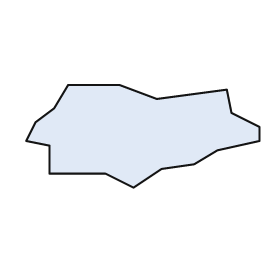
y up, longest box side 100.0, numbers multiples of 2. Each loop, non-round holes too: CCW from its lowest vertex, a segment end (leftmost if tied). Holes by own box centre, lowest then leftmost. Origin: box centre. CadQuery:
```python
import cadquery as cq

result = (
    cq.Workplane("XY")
    .moveTo(-4.0, -22.0)
    .lineTo(8.0, -14.0)
    .lineTo(22.0, -12.0)
    .lineTo(32.0, -6.0)
    .lineTo(50.0, -2.0)
    .lineTo(50.0, 4.0)
    .lineTo(38.0, 10.0)
    .lineTo(36.0, 20.0)
    .lineTo(6.0, 16.0)
    .lineTo(-10.0, 22.0)
    .lineTo(-32.0, 22.0)
    .lineTo(-38.0, 12.0)
    .lineTo(-46.0, 6.0)
    .lineTo(-50.0, -2.0)
    .lineTo(-40.0, -4.0)
    .lineTo(-40.0, -16.0)
    .lineTo(-16.0, -16.0)
    .close()
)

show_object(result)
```